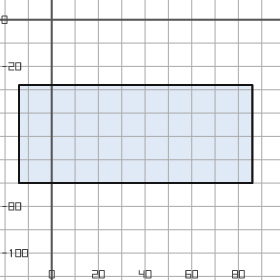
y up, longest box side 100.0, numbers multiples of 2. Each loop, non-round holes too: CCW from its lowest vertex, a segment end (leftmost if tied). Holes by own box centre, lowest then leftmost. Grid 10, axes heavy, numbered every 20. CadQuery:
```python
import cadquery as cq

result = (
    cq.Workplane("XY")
    .moveTo(-14.0, -70.0)
    .lineTo(86.0, -70.0)
    .lineTo(86.0, -28.0)
    .lineTo(-14.0, -28.0)
    .close()
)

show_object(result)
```